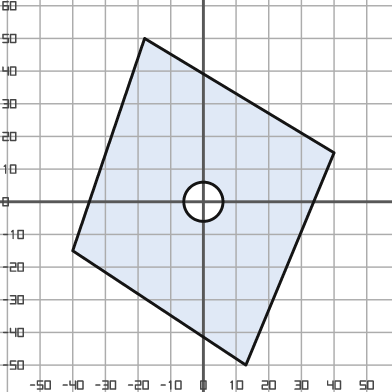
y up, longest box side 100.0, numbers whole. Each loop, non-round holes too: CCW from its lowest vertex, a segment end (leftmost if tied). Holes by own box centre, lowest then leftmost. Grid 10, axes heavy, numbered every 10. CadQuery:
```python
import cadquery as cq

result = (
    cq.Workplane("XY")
    .moveTo(13.0, -50.0)
    .lineTo(40.0, 15.0)
    .lineTo(-18.0, 50.0)
    .lineTo(-40.0, -15.0)
    .close()
    .moveTo(0.0, 0.0)
    .circle(6.0)
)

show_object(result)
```